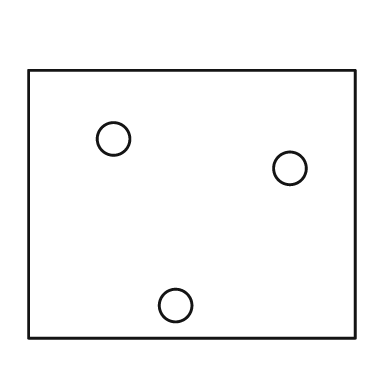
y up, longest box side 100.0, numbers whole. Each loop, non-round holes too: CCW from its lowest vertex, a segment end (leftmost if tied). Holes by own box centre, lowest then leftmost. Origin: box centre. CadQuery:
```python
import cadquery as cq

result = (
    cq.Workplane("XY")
    .moveTo(-50.0, -41.0)
    .lineTo(50.0, -41.0)
    .lineTo(50.0, 41.0)
    .lineTo(-50.0, 41.0)
    .close()
    .moveTo(-5.0, -31.0)
    .circle(5.0)
    .moveTo(30.0, 11.0)
    .circle(5.0)
    .moveTo(-24.0, 20.0)
    .circle(5.0)
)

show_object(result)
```